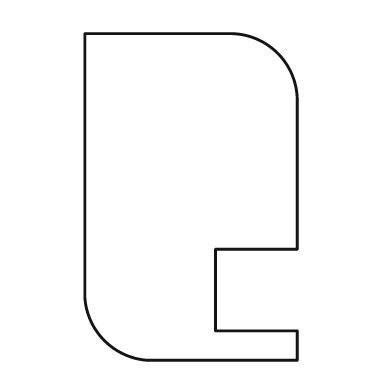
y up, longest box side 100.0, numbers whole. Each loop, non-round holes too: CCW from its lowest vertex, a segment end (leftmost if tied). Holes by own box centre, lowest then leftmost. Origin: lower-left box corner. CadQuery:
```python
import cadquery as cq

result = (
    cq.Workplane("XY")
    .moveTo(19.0, 0.0)
    .lineTo(65.0, 0.0)
    .lineTo(65.0, 9.0)
    .lineTo(40.0, 9.0)
    .lineTo(40.0, 34.0)
    .lineTo(65.0, 34.0)
    .lineTo(65.0, 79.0)
    .threePointArc((59.0, 94.0), (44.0, 100.0))
    .lineTo(0.0, 100.0)
    .lineTo(0.0, 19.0)
    .threePointArc((6.0, 6.0), (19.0, 0.0))
    .close()
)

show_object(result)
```